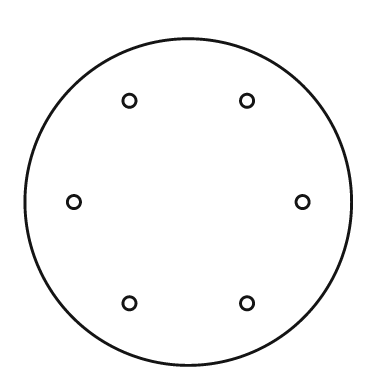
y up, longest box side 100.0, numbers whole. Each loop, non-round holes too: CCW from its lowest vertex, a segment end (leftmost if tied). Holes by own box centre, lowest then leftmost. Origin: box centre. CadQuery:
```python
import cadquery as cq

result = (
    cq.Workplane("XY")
    .moveTo(0.0, 0.0)
    .circle(50.0)
    .moveTo(-18.0, -31.0)
    .circle(2.0)
    .moveTo(18.0, -31.0)
    .circle(2.0)
    .moveTo(-35.0, 0.0)
    .circle(2.0)
    .moveTo(35.0, 0.0)
    .circle(2.0)
    .moveTo(-18.0, 31.0)
    .circle(2.0)
    .moveTo(18.0, 31.0)
    .circle(2.0)
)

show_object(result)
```